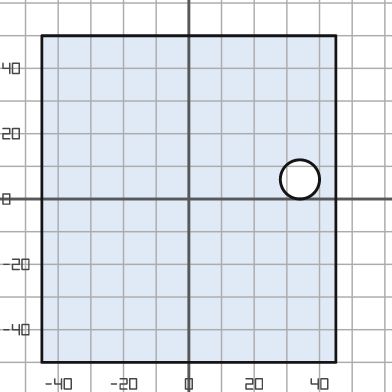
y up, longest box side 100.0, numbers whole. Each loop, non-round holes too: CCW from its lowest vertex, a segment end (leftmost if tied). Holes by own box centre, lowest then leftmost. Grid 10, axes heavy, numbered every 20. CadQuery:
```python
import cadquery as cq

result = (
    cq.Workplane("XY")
    .moveTo(-45.0, -50.0)
    .lineTo(45.0, -50.0)
    .lineTo(45.0, 50.0)
    .lineTo(-45.0, 50.0)
    .close()
    .moveTo(34.0, 6.0)
    .circle(6.0)
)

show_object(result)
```